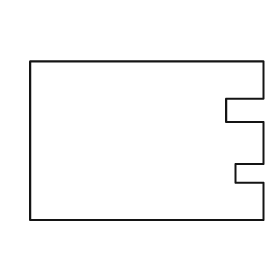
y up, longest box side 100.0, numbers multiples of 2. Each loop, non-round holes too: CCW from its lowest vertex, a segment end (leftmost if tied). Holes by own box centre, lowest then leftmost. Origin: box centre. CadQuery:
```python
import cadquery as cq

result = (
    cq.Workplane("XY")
    .moveTo(-50.0, -34.0)
    .lineTo(50.0, -34.0)
    .lineTo(50.0, -18.0)
    .lineTo(38.0, -18.0)
    .lineTo(38.0, -10.0)
    .lineTo(50.0, -10.0)
    .lineTo(50.0, 8.0)
    .lineTo(34.0, 8.0)
    .lineTo(34.0, 18.0)
    .lineTo(50.0, 18.0)
    .lineTo(50.0, 34.0)
    .lineTo(-50.0, 34.0)
    .close()
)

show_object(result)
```